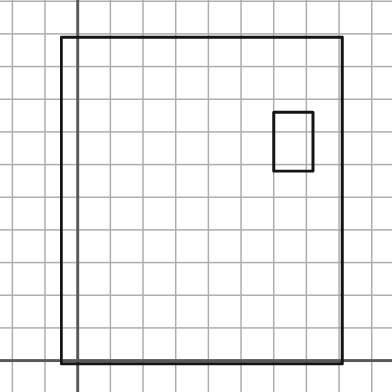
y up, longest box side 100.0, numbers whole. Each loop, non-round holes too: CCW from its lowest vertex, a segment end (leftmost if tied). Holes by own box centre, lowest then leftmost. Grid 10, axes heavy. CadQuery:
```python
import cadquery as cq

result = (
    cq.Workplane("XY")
    .moveTo(-5.0, -1.0)
    .lineTo(81.0, -1.0)
    .lineTo(81.0, 99.0)
    .lineTo(-5.0, 99.0)
    .close()
    .moveTo(60.0, 58.0)
    .lineTo(72.0, 58.0)
    .lineTo(72.0, 76.0)
    .lineTo(60.0, 76.0)
    .close()
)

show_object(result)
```